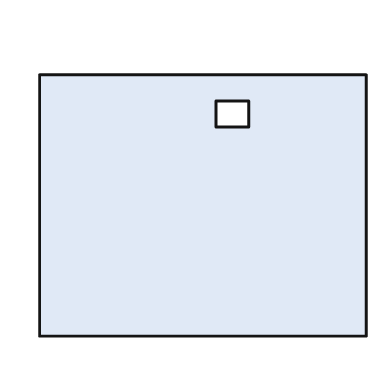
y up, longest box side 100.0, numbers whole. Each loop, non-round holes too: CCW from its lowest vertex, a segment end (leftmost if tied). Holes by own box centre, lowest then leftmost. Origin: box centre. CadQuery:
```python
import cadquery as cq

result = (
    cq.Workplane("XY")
    .moveTo(-50.0, -40.0)
    .lineTo(50.0, -40.0)
    .lineTo(50.0, 40.0)
    .lineTo(-50.0, 40.0)
    .close()
    .moveTo(4.0, 24.0)
    .lineTo(14.0, 24.0)
    .lineTo(14.0, 32.0)
    .lineTo(4.0, 32.0)
    .close()
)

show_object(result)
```